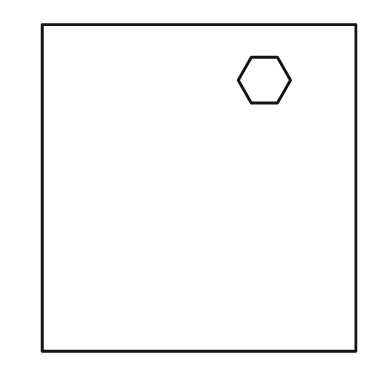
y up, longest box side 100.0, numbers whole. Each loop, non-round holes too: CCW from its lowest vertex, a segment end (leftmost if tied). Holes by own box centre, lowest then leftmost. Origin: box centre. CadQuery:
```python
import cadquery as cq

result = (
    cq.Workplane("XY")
    .moveTo(-48.0, -50.0)
    .lineTo(48.0, -50.0)
    .lineTo(48.0, 50.0)
    .lineTo(-48.0, 50.0)
    .close()
    .moveTo(16.0, 26.0)
    .lineTo(24.0, 26.0)
    .lineTo(28.0, 33.0)
    .lineTo(24.0, 40.0)
    .lineTo(16.0, 40.0)
    .lineTo(12.0, 33.0)
    .close()
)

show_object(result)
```